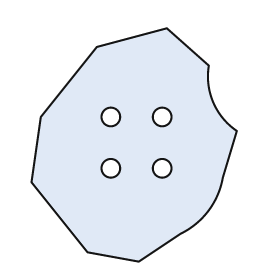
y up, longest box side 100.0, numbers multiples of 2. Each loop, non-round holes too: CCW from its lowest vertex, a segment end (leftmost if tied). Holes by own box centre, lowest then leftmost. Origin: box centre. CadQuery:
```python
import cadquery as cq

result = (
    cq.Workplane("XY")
    .moveTo(2.0, -50.0)
    .lineTo(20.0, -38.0)
    .threePointArc((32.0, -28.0), (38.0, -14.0))
    .lineTo(44.0, 6.0)
    .threePointArc((34.0, 18.0), (32.0, 34.0))
    .lineTo(14.0, 50.0)
    .lineTo(-16.0, 42.0)
    .lineTo(-40.0, 12.0)
    .lineTo(-44.0, -16.0)
    .lineTo(-20.0, -46.0)
    .close()
    .moveTo(-10.0, -10.0)
    .circle(4.0)
    .moveTo(12.0, -10.0)
    .circle(4.0)
    .moveTo(-10.0, 12.0)
    .circle(4.0)
    .moveTo(12.0, 12.0)
    .circle(4.0)
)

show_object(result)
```